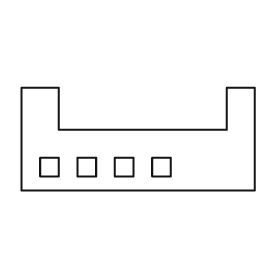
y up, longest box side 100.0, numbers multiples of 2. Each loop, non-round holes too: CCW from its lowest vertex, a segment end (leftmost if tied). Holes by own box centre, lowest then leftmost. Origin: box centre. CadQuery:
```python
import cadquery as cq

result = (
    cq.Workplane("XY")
    .moveTo(-50.0, -22.0)
    .lineTo(50.0, -22.0)
    .lineTo(50.0, 22.0)
    .lineTo(38.0, 22.0)
    .lineTo(38.0, 4.0)
    .lineTo(-34.0, 4.0)
    .lineTo(-34.0, 22.0)
    .lineTo(-50.0, 22.0)
    .close()
    .moveTo(-42.0, -16.0)
    .lineTo(-34.0, -16.0)
    .lineTo(-34.0, -8.0)
    .lineTo(-42.0, -8.0)
    .close()
    .moveTo(-26.0, -16.0)
    .lineTo(-18.0, -16.0)
    .lineTo(-18.0, -8.0)
    .lineTo(-26.0, -8.0)
    .close()
    .moveTo(-10.0, -16.0)
    .lineTo(-2.0, -16.0)
    .lineTo(-2.0, -8.0)
    .lineTo(-10.0, -8.0)
    .close()
    .moveTo(6.0, -16.0)
    .lineTo(14.0, -16.0)
    .lineTo(14.0, -8.0)
    .lineTo(6.0, -8.0)
    .close()
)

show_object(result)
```